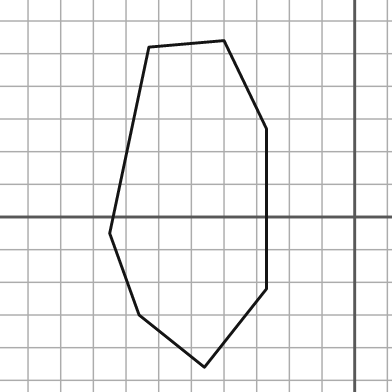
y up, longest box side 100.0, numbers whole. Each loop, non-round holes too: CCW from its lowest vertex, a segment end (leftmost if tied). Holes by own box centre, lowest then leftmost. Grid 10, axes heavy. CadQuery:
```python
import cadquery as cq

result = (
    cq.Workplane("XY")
    .moveTo(-46.0, -46.0)
    .lineTo(-27.0, -22.0)
    .lineTo(-27.0, 27.0)
    .lineTo(-40.0, 54.0)
    .lineTo(-63.0, 52.0)
    .lineTo(-75.0, -5.0)
    .lineTo(-66.0, -30.0)
    .close()
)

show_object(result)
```